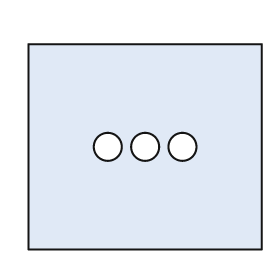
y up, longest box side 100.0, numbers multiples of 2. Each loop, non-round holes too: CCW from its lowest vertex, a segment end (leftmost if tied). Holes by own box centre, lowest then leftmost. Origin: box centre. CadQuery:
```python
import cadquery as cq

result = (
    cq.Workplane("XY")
    .moveTo(-50.0, -44.0)
    .lineTo(50.0, -44.0)
    .lineTo(50.0, 44.0)
    .lineTo(-50.0, 44.0)
    .close()
    .moveTo(-16.0, 0.0)
    .circle(6.0)
    .moveTo(0.0, 0.0)
    .circle(6.0)
    .moveTo(16.0, 0.0)
    .circle(6.0)
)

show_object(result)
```